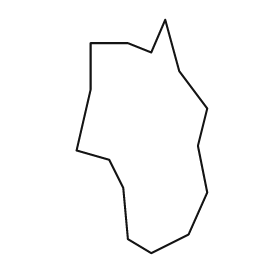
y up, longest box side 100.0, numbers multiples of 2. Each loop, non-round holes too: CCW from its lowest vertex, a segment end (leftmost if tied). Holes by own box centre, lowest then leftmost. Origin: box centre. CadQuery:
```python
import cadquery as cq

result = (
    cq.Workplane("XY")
    .moveTo(4.0, -50.0)
    .lineTo(20.0, -42.0)
    .lineTo(28.0, -24.0)
    .lineTo(24.0, -4.0)
    .lineTo(28.0, 12.0)
    .lineTo(16.0, 28.0)
    .lineTo(10.0, 50.0)
    .lineTo(4.0, 36.0)
    .lineTo(-6.0, 40.0)
    .lineTo(-22.0, 40.0)
    .lineTo(-22.0, 20.0)
    .lineTo(-28.0, -6.0)
    .lineTo(-14.0, -10.0)
    .lineTo(-8.0, -22.0)
    .lineTo(-6.0, -44.0)
    .close()
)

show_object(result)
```